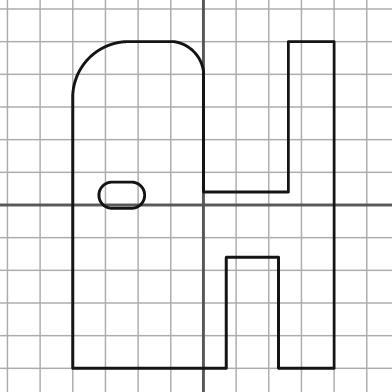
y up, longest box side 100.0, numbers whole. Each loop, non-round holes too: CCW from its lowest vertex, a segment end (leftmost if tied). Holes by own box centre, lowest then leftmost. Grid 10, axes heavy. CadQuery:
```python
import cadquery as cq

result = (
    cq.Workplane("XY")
    .moveTo(-40.0, -50.0)
    .lineTo(7.0, -50.0)
    .lineTo(7.0, -16.0)
    .lineTo(23.0, -16.0)
    .lineTo(23.0, -50.0)
    .lineTo(40.0, -50.0)
    .lineTo(40.0, 50.0)
    .lineTo(26.0, 50.0)
    .lineTo(26.0, 4.0)
    .lineTo(0.0, 4.0)
    .lineTo(0.0, 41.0)
    .threePointArc((-3.0, 47.0), (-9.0, 50.0))
    .lineTo(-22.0, 50.0)
    .threePointArc((-35.0, 45.0), (-40.0, 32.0))
    .close()
    .moveTo(-28.0, -1.0)
    .lineTo(-22.0, -1.0)
    .threePointArc((-18.0, 3.0), (-22.0, 7.0))
    .lineTo(-28.0, 7.0)
    .threePointArc((-32.0, 3.0), (-28.0, -1.0))
    .close()
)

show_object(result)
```